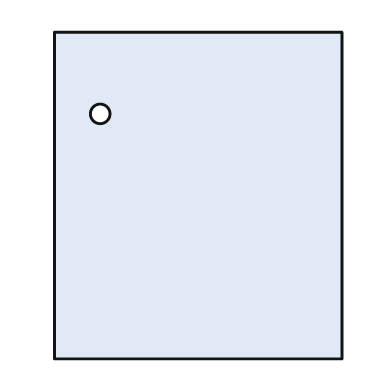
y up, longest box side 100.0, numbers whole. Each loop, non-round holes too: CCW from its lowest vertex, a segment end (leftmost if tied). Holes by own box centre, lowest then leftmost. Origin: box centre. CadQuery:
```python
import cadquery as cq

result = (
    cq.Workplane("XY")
    .moveTo(-44.0, -50.0)
    .lineTo(44.0, -50.0)
    .lineTo(44.0, 50.0)
    .lineTo(-44.0, 50.0)
    .close()
    .moveTo(-30.0, 25.0)
    .circle(3.0)
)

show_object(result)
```